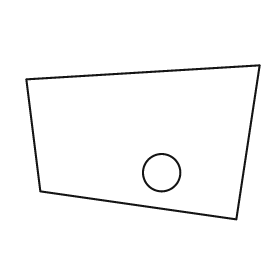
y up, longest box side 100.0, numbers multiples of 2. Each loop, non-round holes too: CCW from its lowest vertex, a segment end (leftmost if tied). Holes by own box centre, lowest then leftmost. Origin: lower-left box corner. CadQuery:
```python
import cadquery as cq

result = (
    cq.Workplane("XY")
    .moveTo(90.0, 0.0)
    .lineTo(100.0, 66.0)
    .lineTo(0.0, 60.0)
    .lineTo(6.0, 12.0)
    .close()
    .moveTo(58.0, 20.0)
    .circle(8.0)
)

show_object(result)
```